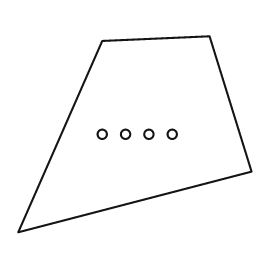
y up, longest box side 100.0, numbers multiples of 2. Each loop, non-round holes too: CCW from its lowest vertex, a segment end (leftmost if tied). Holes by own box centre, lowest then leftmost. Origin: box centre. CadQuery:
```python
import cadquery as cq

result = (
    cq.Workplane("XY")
    .moveTo(-50.0, -42.0)
    .lineTo(50.0, -16.0)
    .lineTo(32.0, 42.0)
    .lineTo(-14.0, 40.0)
    .close()
    .moveTo(-14.0, 0.0)
    .circle(2.0)
    .moveTo(-4.0, 0.0)
    .circle(2.0)
    .moveTo(6.0, 0.0)
    .circle(2.0)
    .moveTo(16.0, 0.0)
    .circle(2.0)
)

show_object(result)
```